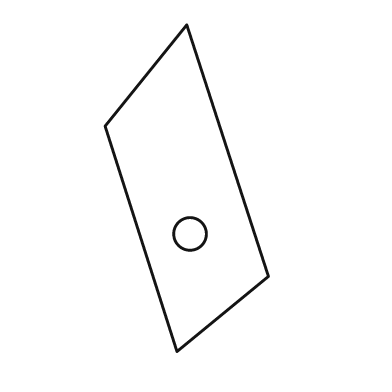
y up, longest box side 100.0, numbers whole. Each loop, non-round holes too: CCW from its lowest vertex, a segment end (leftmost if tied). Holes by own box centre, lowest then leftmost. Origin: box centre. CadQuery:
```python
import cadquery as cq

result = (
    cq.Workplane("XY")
    .moveTo(-3.0, -50.0)
    .lineTo(25.0, -27.0)
    .lineTo(0.0, 50.0)
    .lineTo(-25.0, 19.0)
    .close()
    .moveTo(1.0, -14.0)
    .circle(5.0)
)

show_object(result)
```